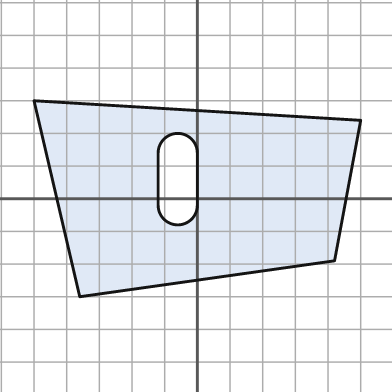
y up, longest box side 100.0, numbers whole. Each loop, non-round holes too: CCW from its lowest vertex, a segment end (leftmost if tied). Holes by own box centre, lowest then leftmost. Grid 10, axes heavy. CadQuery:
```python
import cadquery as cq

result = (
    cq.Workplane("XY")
    .moveTo(-36.0, -30.0)
    .lineTo(42.0, -19.0)
    .lineTo(50.0, 24.0)
    .lineTo(-50.0, 30.0)
    .close()
    .moveTo(-12.0, -2.0)
    .threePointArc((-6.0, -8.0), (0.0, -2.0))
    .lineTo(0.0, 14.0)
    .threePointArc((-6.0, 20.0), (-12.0, 14.0))
    .close()
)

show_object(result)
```